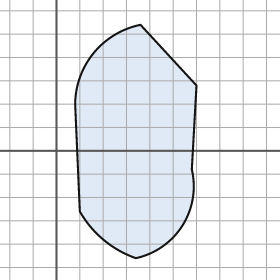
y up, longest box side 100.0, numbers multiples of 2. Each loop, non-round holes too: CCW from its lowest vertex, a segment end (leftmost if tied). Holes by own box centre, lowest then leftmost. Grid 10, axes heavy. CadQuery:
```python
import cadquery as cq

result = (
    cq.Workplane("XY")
    .moveTo(34.0, -46.0)
    .threePointArc((54.0, -32.0), (58.0, -8.0))
    .lineTo(60.0, 28.0)
    .lineTo(36.0, 54.0)
    .threePointArc((16.0, 42.0), (8.0, 20.0))
    .lineTo(10.0, -26.0)
    .threePointArc((20.0, -38.0), (34.0, -46.0))
    .close()
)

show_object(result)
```